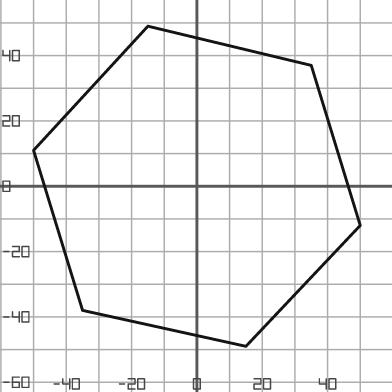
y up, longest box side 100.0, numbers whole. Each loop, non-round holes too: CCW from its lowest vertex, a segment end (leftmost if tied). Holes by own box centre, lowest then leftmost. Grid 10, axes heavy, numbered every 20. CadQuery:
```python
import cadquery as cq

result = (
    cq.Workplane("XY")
    .moveTo(15.0, -49.0)
    .lineTo(50.0, -12.0)
    .lineTo(35.0, 37.0)
    .lineTo(-15.0, 49.0)
    .lineTo(-50.0, 11.0)
    .lineTo(-35.0, -38.0)
    .close()
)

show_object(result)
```